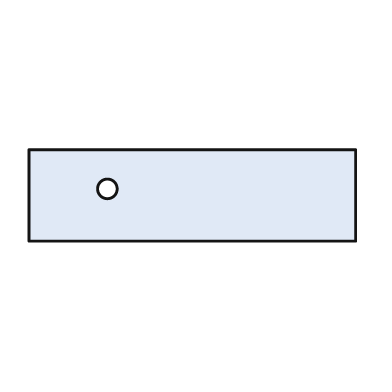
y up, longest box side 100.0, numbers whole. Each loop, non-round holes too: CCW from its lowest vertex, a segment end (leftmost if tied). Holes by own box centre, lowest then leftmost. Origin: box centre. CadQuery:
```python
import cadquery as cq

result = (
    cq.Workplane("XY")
    .moveTo(-50.0, -14.0)
    .lineTo(50.0, -14.0)
    .lineTo(50.0, 14.0)
    .lineTo(-50.0, 14.0)
    .close()
    .moveTo(-26.0, 2.0)
    .circle(3.0)
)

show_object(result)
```